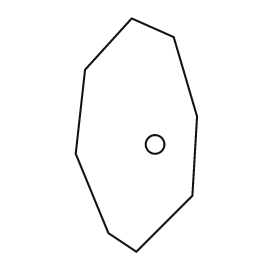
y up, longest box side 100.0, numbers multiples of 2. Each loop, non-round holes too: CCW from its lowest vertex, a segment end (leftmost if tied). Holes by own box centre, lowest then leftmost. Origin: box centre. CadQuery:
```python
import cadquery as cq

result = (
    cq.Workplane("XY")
    .moveTo(0.0, -50.0)
    .lineTo(24.0, -26.0)
    .lineTo(26.0, 8.0)
    .lineTo(16.0, 42.0)
    .lineTo(-2.0, 50.0)
    .lineTo(-22.0, 28.0)
    .lineTo(-26.0, -8.0)
    .lineTo(-12.0, -42.0)
    .close()
    .moveTo(8.0, -4.0)
    .circle(4.0)
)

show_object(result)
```